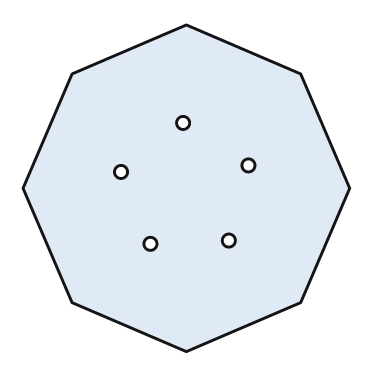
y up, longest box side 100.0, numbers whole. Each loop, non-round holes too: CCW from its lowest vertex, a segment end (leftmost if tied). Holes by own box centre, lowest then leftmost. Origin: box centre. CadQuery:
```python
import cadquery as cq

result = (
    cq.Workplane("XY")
    .moveTo(0.0, -50.0)
    .lineTo(35.0, -35.0)
    .lineTo(50.0, 0.0)
    .lineTo(35.0, 35.0)
    .lineTo(0.0, 50.0)
    .lineTo(-35.0, 35.0)
    .lineTo(-50.0, 0.0)
    .lineTo(-35.0, -35.0)
    .close()
    .moveTo(-11.0, -17.0)
    .circle(2.0)
    .moveTo(13.0, -16.0)
    .circle(2.0)
    .moveTo(-20.0, 5.0)
    .circle(2.0)
    .moveTo(19.0, 7.0)
    .circle(2.0)
    .moveTo(-1.0, 20.0)
    .circle(2.0)
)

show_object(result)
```